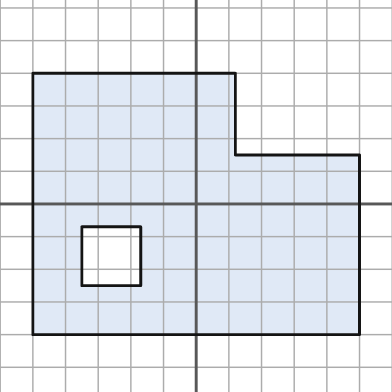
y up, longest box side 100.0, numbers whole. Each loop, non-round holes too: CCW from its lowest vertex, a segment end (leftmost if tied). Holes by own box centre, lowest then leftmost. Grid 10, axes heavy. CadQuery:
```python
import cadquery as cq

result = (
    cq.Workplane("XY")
    .moveTo(-50.0, -40.0)
    .lineTo(50.0, -40.0)
    .lineTo(50.0, 15.0)
    .lineTo(12.0, 15.0)
    .lineTo(12.0, 40.0)
    .lineTo(-50.0, 40.0)
    .close()
    .moveTo(-35.0, -25.0)
    .lineTo(-17.0, -25.0)
    .lineTo(-17.0, -7.0)
    .lineTo(-35.0, -7.0)
    .close()
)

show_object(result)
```